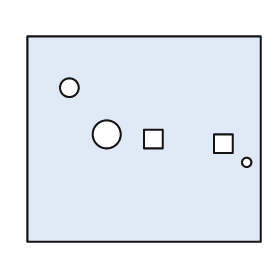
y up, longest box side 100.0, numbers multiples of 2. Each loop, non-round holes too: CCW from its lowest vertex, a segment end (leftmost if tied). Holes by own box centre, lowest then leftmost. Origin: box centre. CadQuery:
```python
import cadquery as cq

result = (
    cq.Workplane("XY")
    .moveTo(-50.0, -44.0)
    .lineTo(50.0, -44.0)
    .lineTo(50.0, 44.0)
    .lineTo(-50.0, 44.0)
    .close()
    .moveTo(44.0, -10.0)
    .circle(2.0)
    .moveTo(30.0, -6.0)
    .lineTo(38.0, -6.0)
    .lineTo(38.0, 2.0)
    .lineTo(30.0, 2.0)
    .close()
    .moveTo(0.0, -4.0)
    .lineTo(8.0, -4.0)
    .lineTo(8.0, 4.0)
    .lineTo(0.0, 4.0)
    .close()
    .moveTo(-16.0, 2.0)
    .circle(6.0)
    .moveTo(-32.0, 22.0)
    .circle(4.0)
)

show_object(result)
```